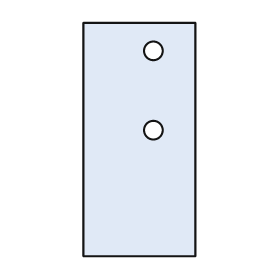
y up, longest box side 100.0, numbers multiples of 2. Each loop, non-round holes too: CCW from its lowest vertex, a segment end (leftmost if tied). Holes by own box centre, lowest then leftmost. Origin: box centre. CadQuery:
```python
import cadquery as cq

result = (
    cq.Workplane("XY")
    .moveTo(-24.0, -50.0)
    .lineTo(24.0, -50.0)
    .lineTo(24.0, 50.0)
    .lineTo(-24.0, 50.0)
    .close()
    .moveTo(6.0, 4.0)
    .circle(4.0)
    .moveTo(6.0, 38.0)
    .circle(4.0)
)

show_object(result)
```